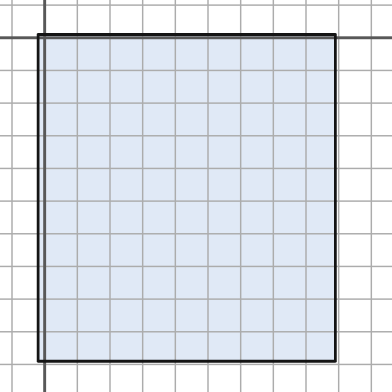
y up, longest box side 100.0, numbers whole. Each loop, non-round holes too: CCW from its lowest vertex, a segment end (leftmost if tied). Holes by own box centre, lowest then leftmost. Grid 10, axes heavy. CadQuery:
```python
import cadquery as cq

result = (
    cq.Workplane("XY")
    .moveTo(-2.0, -99.0)
    .lineTo(89.0, -99.0)
    .lineTo(89.0, 1.0)
    .lineTo(-2.0, 1.0)
    .close()
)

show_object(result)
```